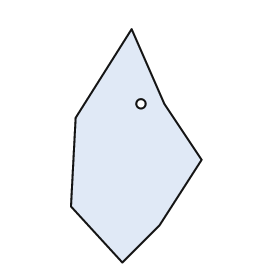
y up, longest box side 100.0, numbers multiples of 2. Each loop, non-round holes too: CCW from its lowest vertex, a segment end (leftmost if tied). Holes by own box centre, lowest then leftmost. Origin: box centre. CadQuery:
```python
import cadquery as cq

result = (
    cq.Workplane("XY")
    .moveTo(-6.0, -50.0)
    .lineTo(10.0, -34.0)
    .lineTo(28.0, -6.0)
    .lineTo(12.0, 18.0)
    .lineTo(-2.0, 50.0)
    .lineTo(-26.0, 12.0)
    .lineTo(-28.0, -26.0)
    .close()
    .moveTo(2.0, 18.0)
    .circle(2.0)
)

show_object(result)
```